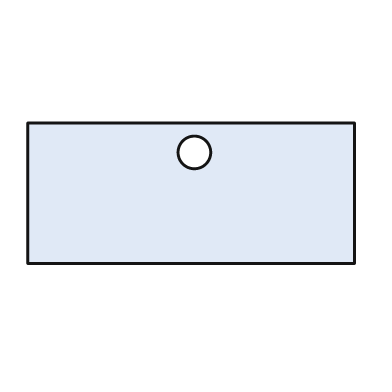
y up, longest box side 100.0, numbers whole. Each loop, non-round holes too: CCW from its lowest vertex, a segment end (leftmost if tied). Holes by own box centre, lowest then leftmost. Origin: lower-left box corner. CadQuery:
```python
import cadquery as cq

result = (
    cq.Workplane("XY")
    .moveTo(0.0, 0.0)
    .lineTo(100.0, 0.0)
    .lineTo(100.0, 43.0)
    .lineTo(0.0, 43.0)
    .close()
    .moveTo(51.0, 34.0)
    .circle(5.0)
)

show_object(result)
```